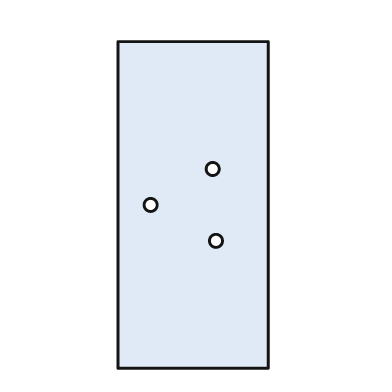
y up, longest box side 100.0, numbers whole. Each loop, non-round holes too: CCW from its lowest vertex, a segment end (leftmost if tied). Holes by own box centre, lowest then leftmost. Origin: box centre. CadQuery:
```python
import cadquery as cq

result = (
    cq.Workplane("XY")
    .moveTo(-23.0, -50.0)
    .lineTo(23.0, -50.0)
    .lineTo(23.0, 50.0)
    .lineTo(-23.0, 50.0)
    .close()
    .moveTo(7.0, -11.0)
    .circle(2.0)
    .moveTo(-13.0, 0.0)
    .circle(2.0)
    .moveTo(6.0, 11.0)
    .circle(2.0)
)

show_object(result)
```